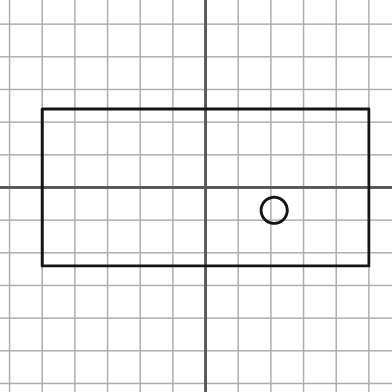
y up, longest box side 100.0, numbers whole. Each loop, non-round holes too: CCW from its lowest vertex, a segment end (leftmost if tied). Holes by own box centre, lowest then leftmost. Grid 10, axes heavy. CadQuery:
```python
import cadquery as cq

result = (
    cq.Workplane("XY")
    .moveTo(-50.0, -24.0)
    .lineTo(50.0, -24.0)
    .lineTo(50.0, 24.0)
    .lineTo(-50.0, 24.0)
    .close()
    .moveTo(21.0, -7.0)
    .circle(4.0)
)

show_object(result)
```